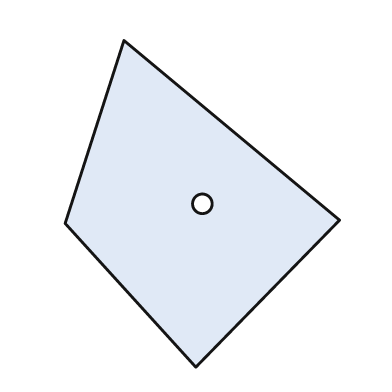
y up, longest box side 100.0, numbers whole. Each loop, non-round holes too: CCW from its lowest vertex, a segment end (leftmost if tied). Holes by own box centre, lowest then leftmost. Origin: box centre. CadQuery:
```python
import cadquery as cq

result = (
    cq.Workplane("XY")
    .moveTo(-2.0, -50.0)
    .lineTo(42.0, -5.0)
    .lineTo(-24.0, 50.0)
    .lineTo(-42.0, -6.0)
    .close()
    .moveTo(0.0, 0.0)
    .circle(3.0)
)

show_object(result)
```